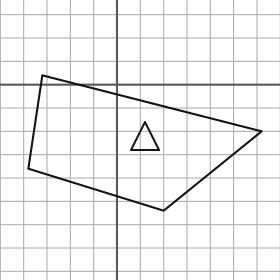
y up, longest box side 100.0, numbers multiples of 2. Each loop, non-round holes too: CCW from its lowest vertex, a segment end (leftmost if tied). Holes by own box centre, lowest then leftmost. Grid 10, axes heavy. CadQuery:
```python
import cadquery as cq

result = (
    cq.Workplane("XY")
    .moveTo(20.0, -54.0)
    .lineTo(62.0, -20.0)
    .lineTo(-32.0, 4.0)
    .lineTo(-38.0, -36.0)
    .close()
    .moveTo(6.0, -28.0)
    .lineTo(18.0, -28.0)
    .lineTo(12.0, -16.0)
    .close()
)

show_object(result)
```